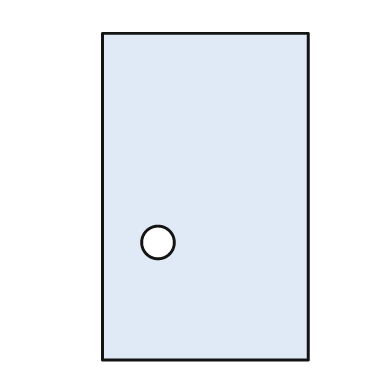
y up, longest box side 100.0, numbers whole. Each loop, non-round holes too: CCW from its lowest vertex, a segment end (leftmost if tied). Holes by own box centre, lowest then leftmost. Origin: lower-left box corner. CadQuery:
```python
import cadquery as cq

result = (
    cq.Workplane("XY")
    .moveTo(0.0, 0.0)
    .lineTo(63.0, 0.0)
    .lineTo(63.0, 100.0)
    .lineTo(0.0, 100.0)
    .close()
    .moveTo(17.0, 36.0)
    .circle(5.0)
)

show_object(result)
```